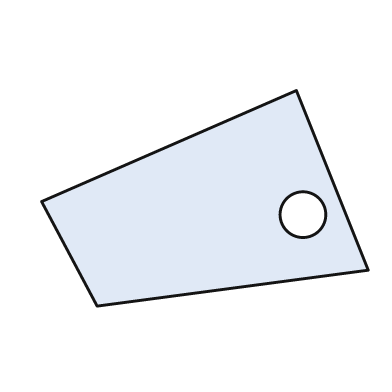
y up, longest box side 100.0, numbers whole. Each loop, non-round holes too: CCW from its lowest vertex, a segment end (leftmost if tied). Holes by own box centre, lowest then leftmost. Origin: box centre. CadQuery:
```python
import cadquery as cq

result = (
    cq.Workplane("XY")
    .moveTo(-33.0, -33.0)
    .lineTo(50.0, -22.0)
    .lineTo(28.0, 33.0)
    .lineTo(-50.0, -1.0)
    .close()
    .moveTo(30.0, -5.0)
    .circle(7.0)
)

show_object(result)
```